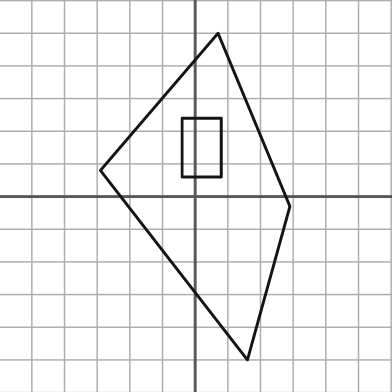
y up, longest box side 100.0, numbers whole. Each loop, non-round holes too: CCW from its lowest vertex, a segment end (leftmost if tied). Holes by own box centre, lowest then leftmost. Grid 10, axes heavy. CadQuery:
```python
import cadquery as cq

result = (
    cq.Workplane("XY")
    .moveTo(16.0, -50.0)
    .lineTo(29.0, -3.0)
    .lineTo(7.0, 50.0)
    .lineTo(-29.0, 8.0)
    .close()
    .moveTo(-4.0, 6.0)
    .lineTo(8.0, 6.0)
    .lineTo(8.0, 24.0)
    .lineTo(-4.0, 24.0)
    .close()
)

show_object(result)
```